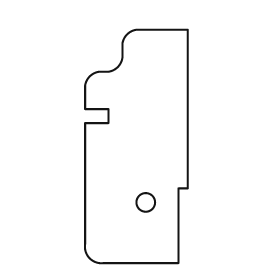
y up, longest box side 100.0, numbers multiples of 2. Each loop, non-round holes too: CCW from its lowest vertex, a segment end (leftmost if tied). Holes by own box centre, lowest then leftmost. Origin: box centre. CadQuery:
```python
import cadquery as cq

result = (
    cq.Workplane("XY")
    .moveTo(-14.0, -50.0)
    .lineTo(18.0, -50.0)
    .lineTo(18.0, -18.0)
    .lineTo(22.0, -18.0)
    .lineTo(22.0, 50.0)
    .lineTo(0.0, 50.0)
    .threePointArc((-4.0, 48.0), (-6.0, 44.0))
    .lineTo(-6.0, 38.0)
    .threePointArc((-8.0, 34.0), (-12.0, 32.0))
    .lineTo(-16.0, 32.0)
    .threePointArc((-20.0, 30.0), (-22.0, 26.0))
    .lineTo(-22.0, 16.0)
    .lineTo(-12.0, 16.0)
    .lineTo(-12.0, 10.0)
    .lineTo(-22.0, 10.0)
    .lineTo(-22.0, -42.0)
    .threePointArc((-20.0, -48.0), (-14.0, -50.0))
    .close()
    .moveTo(4.0, -24.0)
    .circle(4.0)
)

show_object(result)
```